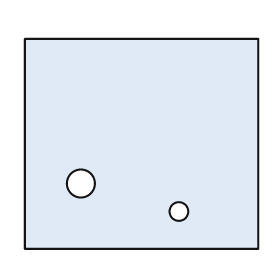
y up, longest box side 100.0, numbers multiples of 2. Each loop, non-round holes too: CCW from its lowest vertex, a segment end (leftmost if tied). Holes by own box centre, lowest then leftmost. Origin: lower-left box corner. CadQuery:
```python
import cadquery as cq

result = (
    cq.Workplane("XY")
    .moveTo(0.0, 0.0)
    .lineTo(100.0, 0.0)
    .lineTo(100.0, 90.0)
    .lineTo(0.0, 90.0)
    .close()
    .moveTo(66.0, 16.0)
    .circle(4.0)
    .moveTo(24.0, 28.0)
    .circle(6.0)
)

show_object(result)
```